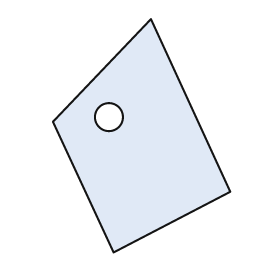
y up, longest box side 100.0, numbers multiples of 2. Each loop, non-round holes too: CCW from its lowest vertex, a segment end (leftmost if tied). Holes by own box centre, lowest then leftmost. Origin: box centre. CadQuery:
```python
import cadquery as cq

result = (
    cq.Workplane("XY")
    .moveTo(-12.0, -50.0)
    .lineTo(38.0, -24.0)
    .lineTo(4.0, 50.0)
    .lineTo(-38.0, 6.0)
    .close()
    .moveTo(-14.0, 8.0)
    .circle(6.0)
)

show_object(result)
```